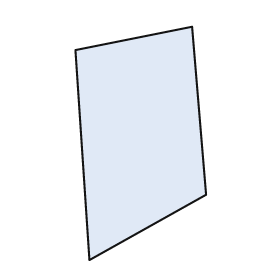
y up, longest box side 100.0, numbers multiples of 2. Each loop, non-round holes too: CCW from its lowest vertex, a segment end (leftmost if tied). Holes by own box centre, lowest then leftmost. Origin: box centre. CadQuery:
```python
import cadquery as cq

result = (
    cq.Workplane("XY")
    .moveTo(-22.0, -50.0)
    .lineTo(28.0, -22.0)
    .lineTo(22.0, 50.0)
    .lineTo(-28.0, 40.0)
    .close()
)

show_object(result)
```